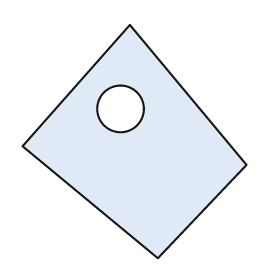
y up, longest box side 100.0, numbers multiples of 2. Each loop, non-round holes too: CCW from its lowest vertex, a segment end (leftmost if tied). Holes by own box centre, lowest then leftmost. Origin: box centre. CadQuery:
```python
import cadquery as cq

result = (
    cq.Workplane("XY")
    .moveTo(10.0, -50.0)
    .lineTo(48.0, -10.0)
    .lineTo(-2.0, 50.0)
    .lineTo(-48.0, -2.0)
    .close()
    .moveTo(-6.0, 14.0)
    .circle(10.0)
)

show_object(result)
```